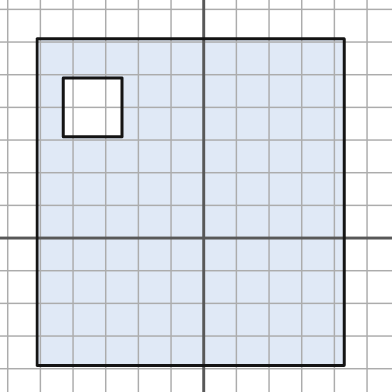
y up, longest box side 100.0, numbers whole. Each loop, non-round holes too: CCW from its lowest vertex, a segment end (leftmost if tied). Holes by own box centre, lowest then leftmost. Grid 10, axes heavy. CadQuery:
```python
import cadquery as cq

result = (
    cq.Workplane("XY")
    .moveTo(-51.0, -39.0)
    .lineTo(43.0, -39.0)
    .lineTo(43.0, 61.0)
    .lineTo(-51.0, 61.0)
    .close()
    .moveTo(-43.0, 31.0)
    .lineTo(-25.0, 31.0)
    .lineTo(-25.0, 49.0)
    .lineTo(-43.0, 49.0)
    .close()
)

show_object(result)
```